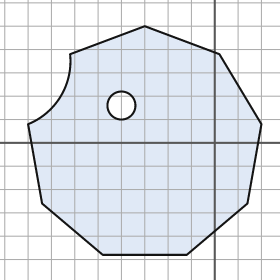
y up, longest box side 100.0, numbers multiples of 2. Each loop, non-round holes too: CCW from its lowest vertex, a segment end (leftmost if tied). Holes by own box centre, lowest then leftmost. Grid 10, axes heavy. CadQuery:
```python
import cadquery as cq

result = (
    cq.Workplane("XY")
    .moveTo(-48.0, -48.0)
    .lineTo(-12.0, -48.0)
    .lineTo(14.0, -26.0)
    .lineTo(20.0, 8.0)
    .lineTo(2.0, 38.0)
    .lineTo(-30.0, 50.0)
    .lineTo(-62.0, 38.0)
    .threePointArc((-66.0, 20.0), (-80.0, 8.0))
    .lineTo(-74.0, -26.0)
    .close()
    .moveTo(-40.0, 16.0)
    .circle(6.0)
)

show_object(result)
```